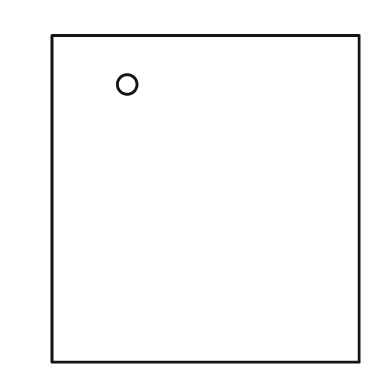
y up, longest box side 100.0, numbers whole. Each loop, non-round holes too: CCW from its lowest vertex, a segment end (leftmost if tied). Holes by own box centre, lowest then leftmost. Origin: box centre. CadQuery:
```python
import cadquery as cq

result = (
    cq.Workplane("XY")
    .moveTo(-47.0, -50.0)
    .lineTo(47.0, -50.0)
    .lineTo(47.0, 50.0)
    .lineTo(-47.0, 50.0)
    .close()
    .moveTo(-24.0, 35.0)
    .circle(3.0)
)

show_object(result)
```